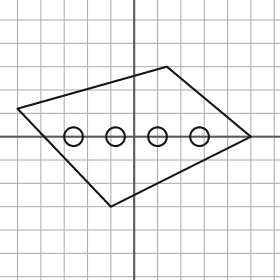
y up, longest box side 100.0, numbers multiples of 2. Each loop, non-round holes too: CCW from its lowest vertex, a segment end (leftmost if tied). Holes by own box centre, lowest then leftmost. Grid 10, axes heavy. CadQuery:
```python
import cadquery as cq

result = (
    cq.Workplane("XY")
    .moveTo(-10.0, -30.0)
    .lineTo(50.0, 0.0)
    .lineTo(14.0, 30.0)
    .lineTo(-50.0, 12.0)
    .close()
    .moveTo(-26.0, 0.0)
    .circle(4.0)
    .moveTo(-8.0, 0.0)
    .circle(4.0)
    .moveTo(10.0, 0.0)
    .circle(4.0)
    .moveTo(28.0, 0.0)
    .circle(4.0)
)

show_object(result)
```